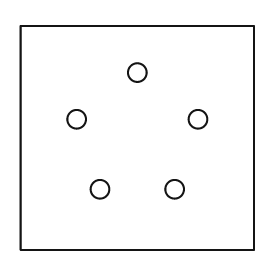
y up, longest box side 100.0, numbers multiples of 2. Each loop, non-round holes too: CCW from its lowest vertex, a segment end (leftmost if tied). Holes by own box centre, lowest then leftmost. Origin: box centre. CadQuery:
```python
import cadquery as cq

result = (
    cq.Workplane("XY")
    .moveTo(-50.0, -48.0)
    .lineTo(50.0, -48.0)
    .lineTo(50.0, 48.0)
    .lineTo(-50.0, 48.0)
    .close()
    .moveTo(-16.0, -22.0)
    .circle(4.0)
    .moveTo(16.0, -22.0)
    .circle(4.0)
    .moveTo(-26.0, 8.0)
    .circle(4.0)
    .moveTo(26.0, 8.0)
    .circle(4.0)
    .moveTo(0.0, 28.0)
    .circle(4.0)
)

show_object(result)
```